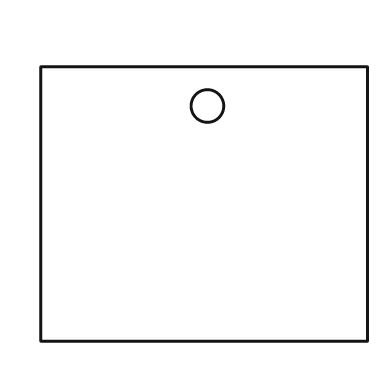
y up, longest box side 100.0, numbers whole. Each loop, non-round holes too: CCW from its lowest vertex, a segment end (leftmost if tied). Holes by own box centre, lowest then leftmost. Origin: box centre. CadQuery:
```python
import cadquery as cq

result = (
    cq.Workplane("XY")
    .moveTo(-50.0, -42.0)
    .lineTo(50.0, -42.0)
    .lineTo(50.0, 42.0)
    .lineTo(-50.0, 42.0)
    .close()
    .moveTo(1.0, 30.0)
    .circle(5.0)
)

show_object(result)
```